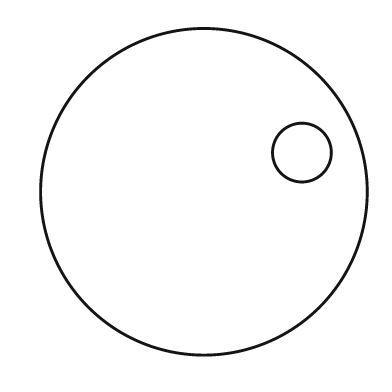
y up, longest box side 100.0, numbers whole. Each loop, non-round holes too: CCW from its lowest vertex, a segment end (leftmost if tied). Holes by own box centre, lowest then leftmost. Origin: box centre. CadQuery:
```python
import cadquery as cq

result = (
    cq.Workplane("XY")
    .moveTo(0.0, 0.0)
    .circle(50.0)
    .moveTo(30.0, 12.0)
    .circle(9.0)
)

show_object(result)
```